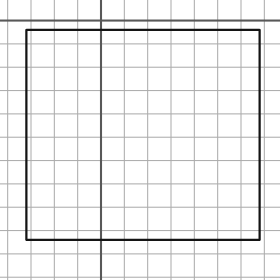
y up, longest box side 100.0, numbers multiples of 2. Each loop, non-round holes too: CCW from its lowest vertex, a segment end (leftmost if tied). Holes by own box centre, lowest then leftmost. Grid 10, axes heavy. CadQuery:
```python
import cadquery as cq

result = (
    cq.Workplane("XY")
    .moveTo(-32.0, -94.0)
    .lineTo(68.0, -94.0)
    .lineTo(68.0, -4.0)
    .lineTo(-32.0, -4.0)
    .close()
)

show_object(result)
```